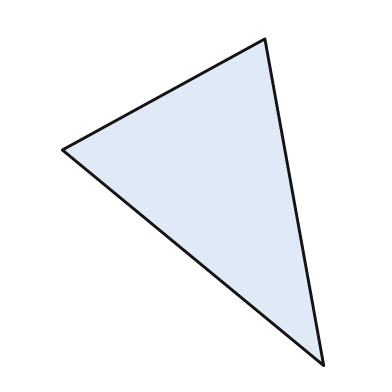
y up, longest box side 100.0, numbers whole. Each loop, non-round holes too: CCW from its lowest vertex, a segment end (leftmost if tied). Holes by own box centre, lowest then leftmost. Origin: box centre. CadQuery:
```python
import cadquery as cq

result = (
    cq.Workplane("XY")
    .moveTo(40.0, -50.0)
    .lineTo(22.0, 50.0)
    .lineTo(-40.0, 16.0)
    .close()
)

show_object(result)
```